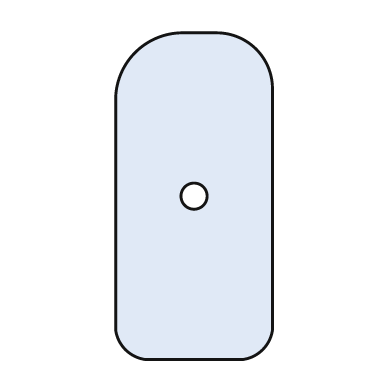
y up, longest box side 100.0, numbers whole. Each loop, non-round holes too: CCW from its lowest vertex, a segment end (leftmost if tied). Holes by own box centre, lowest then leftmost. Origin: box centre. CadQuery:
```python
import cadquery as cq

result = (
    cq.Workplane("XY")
    .moveTo(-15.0, -50.0)
    .lineTo(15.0, -50.0)
    .threePointArc((21.0, -47.0), (24.0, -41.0))
    .lineTo(24.0, 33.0)
    .threePointArc((19.0, 45.0), (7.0, 50.0))
    .lineTo(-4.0, 50.0)
    .threePointArc((-18.0, 44.0), (-24.0, 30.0))
    .lineTo(-24.0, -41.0)
    .threePointArc((-21.0, -47.0), (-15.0, -50.0))
    .close()
    .moveTo(0.0, 0.0)
    .circle(4.0)
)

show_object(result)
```